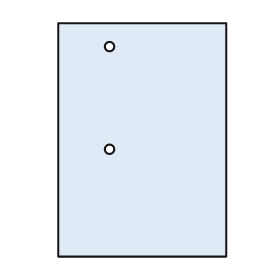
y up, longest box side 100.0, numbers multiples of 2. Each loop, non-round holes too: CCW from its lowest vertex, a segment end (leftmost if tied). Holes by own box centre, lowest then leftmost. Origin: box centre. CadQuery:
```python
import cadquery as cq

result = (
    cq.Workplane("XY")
    .moveTo(-36.0, -50.0)
    .lineTo(36.0, -50.0)
    .lineTo(36.0, 50.0)
    .lineTo(-36.0, 50.0)
    .close()
    .moveTo(-14.0, -4.0)
    .circle(2.0)
    .moveTo(-14.0, 40.0)
    .circle(2.0)
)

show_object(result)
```